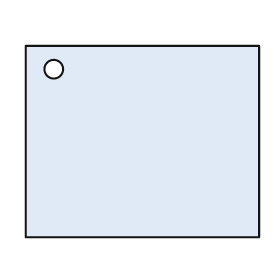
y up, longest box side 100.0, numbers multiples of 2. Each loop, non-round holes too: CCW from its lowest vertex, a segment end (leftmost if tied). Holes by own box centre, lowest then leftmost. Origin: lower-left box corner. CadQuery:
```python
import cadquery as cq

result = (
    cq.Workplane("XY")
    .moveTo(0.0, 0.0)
    .lineTo(100.0, 0.0)
    .lineTo(100.0, 82.0)
    .lineTo(0.0, 82.0)
    .close()
    .moveTo(12.0, 72.0)
    .circle(4.0)
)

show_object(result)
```